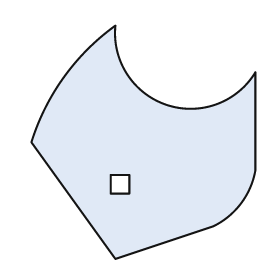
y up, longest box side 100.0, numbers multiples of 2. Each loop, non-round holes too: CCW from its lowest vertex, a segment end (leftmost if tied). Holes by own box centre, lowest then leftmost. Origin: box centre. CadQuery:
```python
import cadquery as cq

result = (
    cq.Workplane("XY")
    .moveTo(-12.0, -50.0)
    .lineTo(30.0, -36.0)
    .threePointArc((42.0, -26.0), (48.0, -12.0))
    .lineTo(48.0, 30.0)
    .threePointArc((10.0, 16.0), (-12.0, 50.0))
    .threePointArc((-34.0, 28.0), (-48.0, 0.0))
    .close()
    .moveTo(-14.0, -22.0)
    .lineTo(-6.0, -22.0)
    .lineTo(-6.0, -14.0)
    .lineTo(-14.0, -14.0)
    .close()
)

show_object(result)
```